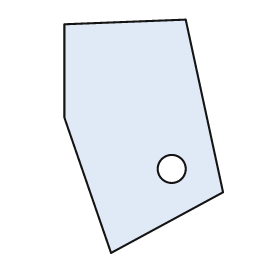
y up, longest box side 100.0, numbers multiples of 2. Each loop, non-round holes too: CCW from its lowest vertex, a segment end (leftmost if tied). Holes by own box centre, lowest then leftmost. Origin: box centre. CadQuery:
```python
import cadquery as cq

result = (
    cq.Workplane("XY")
    .moveTo(-14.0, -50.0)
    .lineTo(34.0, -24.0)
    .lineTo(18.0, 50.0)
    .lineTo(-34.0, 48.0)
    .lineTo(-34.0, 8.0)
    .close()
    .moveTo(12.0, -14.0)
    .circle(6.0)
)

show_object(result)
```